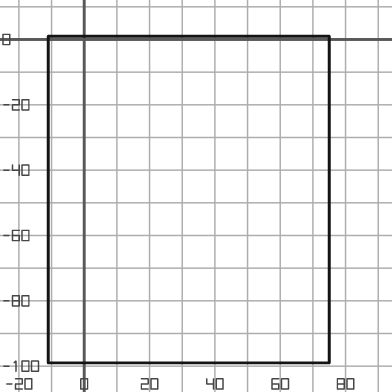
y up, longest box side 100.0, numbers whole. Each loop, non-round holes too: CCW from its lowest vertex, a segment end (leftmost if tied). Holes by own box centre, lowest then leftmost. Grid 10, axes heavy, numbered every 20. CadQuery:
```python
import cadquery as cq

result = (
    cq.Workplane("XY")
    .moveTo(-11.0, -99.0)
    .lineTo(75.0, -99.0)
    .lineTo(75.0, 1.0)
    .lineTo(-11.0, 1.0)
    .close()
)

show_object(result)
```